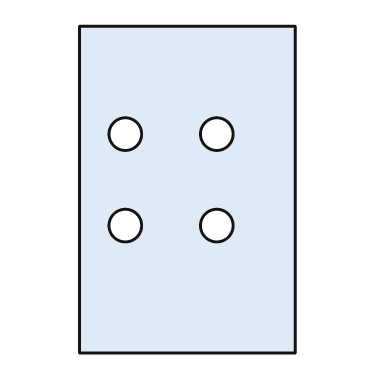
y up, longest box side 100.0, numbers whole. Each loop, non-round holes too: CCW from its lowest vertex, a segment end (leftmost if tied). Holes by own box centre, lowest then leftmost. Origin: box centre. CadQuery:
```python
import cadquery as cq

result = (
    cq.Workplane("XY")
    .moveTo(-33.0, -50.0)
    .lineTo(33.0, -50.0)
    .lineTo(33.0, 50.0)
    .lineTo(-33.0, 50.0)
    .close()
    .moveTo(-19.0, -11.0)
    .circle(5.0)
    .moveTo(9.0, -11.0)
    .circle(5.0)
    .moveTo(-19.0, 17.0)
    .circle(5.0)
    .moveTo(9.0, 17.0)
    .circle(5.0)
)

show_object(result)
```